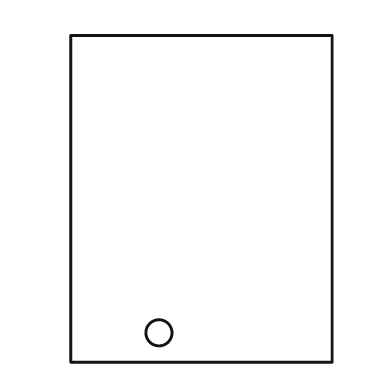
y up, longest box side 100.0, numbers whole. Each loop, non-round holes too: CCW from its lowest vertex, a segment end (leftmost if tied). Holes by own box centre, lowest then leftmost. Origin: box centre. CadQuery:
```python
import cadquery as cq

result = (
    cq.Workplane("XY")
    .moveTo(-40.0, -50.0)
    .lineTo(40.0, -50.0)
    .lineTo(40.0, 50.0)
    .lineTo(-40.0, 50.0)
    .close()
    .moveTo(-13.0, -41.0)
    .circle(4.0)
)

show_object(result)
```